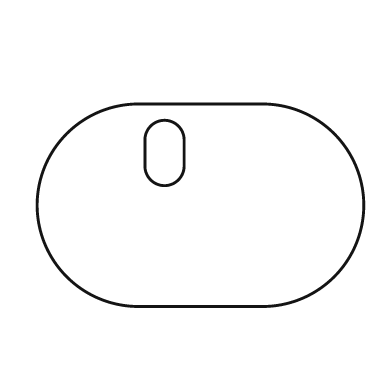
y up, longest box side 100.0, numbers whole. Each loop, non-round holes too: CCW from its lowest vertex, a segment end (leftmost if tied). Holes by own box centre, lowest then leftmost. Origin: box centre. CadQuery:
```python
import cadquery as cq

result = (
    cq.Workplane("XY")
    .moveTo(-19.0, -31.0)
    .lineTo(19.0, -31.0)
    .threePointArc((50.0, 0.0), (19.0, 31.0))
    .lineTo(-19.0, 31.0)
    .threePointArc((-50.0, 0.0), (-19.0, -31.0))
    .close()
    .moveTo(-17.0, 12.0)
    .threePointArc((-11.0, 6.0), (-5.0, 12.0))
    .lineTo(-5.0, 20.0)
    .threePointArc((-11.0, 26.0), (-17.0, 20.0))
    .close()
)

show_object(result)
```